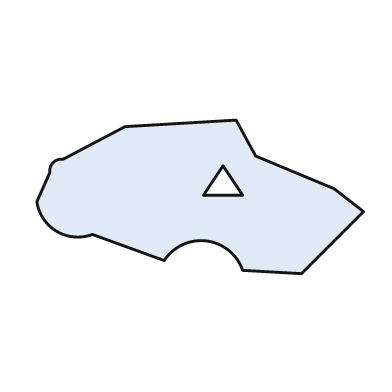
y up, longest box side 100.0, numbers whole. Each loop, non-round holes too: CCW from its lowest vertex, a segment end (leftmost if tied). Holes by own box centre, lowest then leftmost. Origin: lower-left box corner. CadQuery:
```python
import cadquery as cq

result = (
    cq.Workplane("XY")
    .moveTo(81.0, 0.0)
    .lineTo(100.0, 19.0)
    .lineTo(91.0, 26.0)
    .lineTo(67.0, 36.0)
    .lineTo(61.0, 47.0)
    .lineTo(27.0, 45.0)
    .lineTo(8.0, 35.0)
    .threePointArc((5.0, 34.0), (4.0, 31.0))
    .lineTo(0.0, 22.0)
    .threePointArc((6.0, 13.0), (17.0, 12.0))
    .lineTo(39.0, 4.0)
    .threePointArc((52.0, 10.0), (63.0, 1.0))
    .close()
    .moveTo(51.0, 24.0)
    .lineTo(63.0, 24.0)
    .lineTo(57.0, 33.0)
    .close()
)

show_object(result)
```